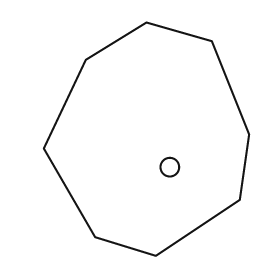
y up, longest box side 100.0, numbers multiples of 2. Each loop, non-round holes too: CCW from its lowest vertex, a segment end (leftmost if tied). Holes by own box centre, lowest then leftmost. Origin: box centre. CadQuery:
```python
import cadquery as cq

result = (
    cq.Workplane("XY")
    .moveTo(4.0, -50.0)
    .lineTo(40.0, -26.0)
    .lineTo(44.0, 2.0)
    .lineTo(28.0, 42.0)
    .lineTo(0.0, 50.0)
    .lineTo(-26.0, 34.0)
    .lineTo(-44.0, -4.0)
    .lineTo(-22.0, -42.0)
    .close()
    .moveTo(10.0, -12.0)
    .circle(4.0)
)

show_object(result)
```